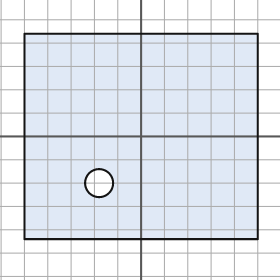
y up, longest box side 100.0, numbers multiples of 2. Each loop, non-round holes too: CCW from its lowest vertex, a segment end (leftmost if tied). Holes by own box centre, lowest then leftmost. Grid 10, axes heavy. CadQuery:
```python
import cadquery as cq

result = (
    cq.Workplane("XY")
    .moveTo(-50.0, -44.0)
    .lineTo(50.0, -44.0)
    .lineTo(50.0, 44.0)
    .lineTo(-50.0, 44.0)
    .close()
    .moveTo(-18.0, -20.0)
    .circle(6.0)
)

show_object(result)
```